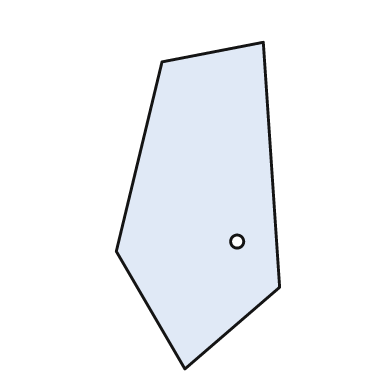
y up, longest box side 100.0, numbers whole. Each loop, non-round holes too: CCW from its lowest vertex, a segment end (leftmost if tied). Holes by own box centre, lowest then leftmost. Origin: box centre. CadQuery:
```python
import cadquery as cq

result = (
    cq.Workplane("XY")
    .moveTo(-4.0, -50.0)
    .lineTo(25.0, -25.0)
    .lineTo(20.0, 50.0)
    .lineTo(-11.0, 44.0)
    .lineTo(-25.0, -14.0)
    .close()
    .moveTo(12.0, -11.0)
    .circle(2.0)
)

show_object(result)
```